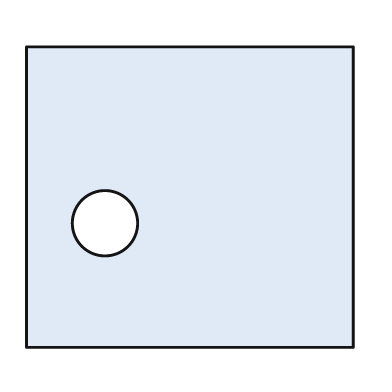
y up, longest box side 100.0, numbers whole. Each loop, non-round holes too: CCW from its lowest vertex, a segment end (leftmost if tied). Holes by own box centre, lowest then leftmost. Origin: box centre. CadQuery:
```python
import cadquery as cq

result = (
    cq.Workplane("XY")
    .moveTo(-50.0, -46.0)
    .lineTo(50.0, -46.0)
    .lineTo(50.0, 46.0)
    .lineTo(-50.0, 46.0)
    .close()
    .moveTo(-26.0, -8.0)
    .circle(10.0)
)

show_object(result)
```